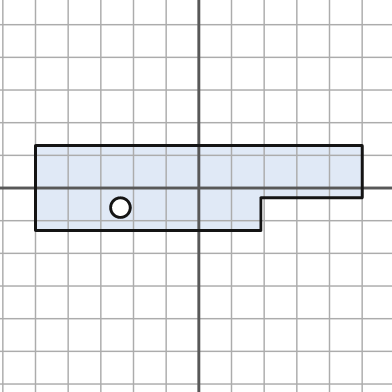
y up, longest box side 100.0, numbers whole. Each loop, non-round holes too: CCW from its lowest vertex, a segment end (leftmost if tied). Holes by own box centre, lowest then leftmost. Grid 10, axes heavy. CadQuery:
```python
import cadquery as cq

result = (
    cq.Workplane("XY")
    .moveTo(-50.0, -13.0)
    .lineTo(19.0, -13.0)
    .lineTo(19.0, -3.0)
    .lineTo(50.0, -3.0)
    .lineTo(50.0, 13.0)
    .lineTo(-50.0, 13.0)
    .close()
    .moveTo(-24.0, -6.0)
    .circle(3.0)
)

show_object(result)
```